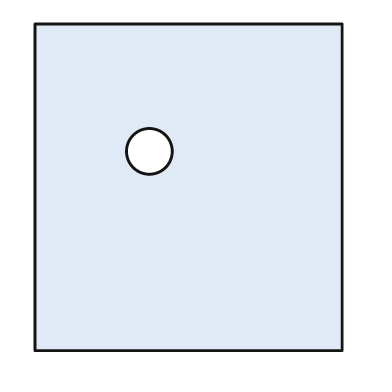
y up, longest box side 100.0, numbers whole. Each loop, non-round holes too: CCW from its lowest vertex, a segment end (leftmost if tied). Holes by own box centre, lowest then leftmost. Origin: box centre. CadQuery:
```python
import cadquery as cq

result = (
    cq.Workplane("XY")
    .moveTo(-47.0, -50.0)
    .lineTo(47.0, -50.0)
    .lineTo(47.0, 50.0)
    .lineTo(-47.0, 50.0)
    .close()
    .moveTo(-12.0, 11.0)
    .circle(7.0)
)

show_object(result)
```